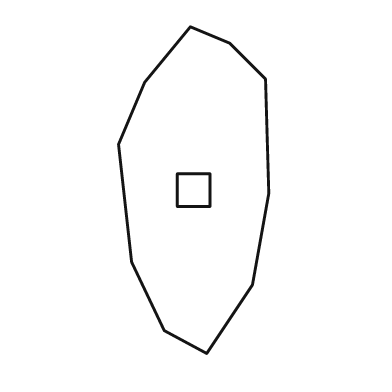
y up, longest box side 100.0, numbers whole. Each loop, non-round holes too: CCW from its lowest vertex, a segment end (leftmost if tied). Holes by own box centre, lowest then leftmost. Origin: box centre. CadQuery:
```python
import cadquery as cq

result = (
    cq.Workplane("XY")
    .moveTo(4.0, -50.0)
    .lineTo(18.0, -29.0)
    .lineTo(23.0, -1.0)
    .lineTo(22.0, 34.0)
    .lineTo(11.0, 45.0)
    .lineTo(-1.0, 50.0)
    .lineTo(-15.0, 33.0)
    .lineTo(-23.0, 14.0)
    .lineTo(-19.0, -22.0)
    .lineTo(-9.0, -43.0)
    .close()
    .moveTo(-5.0, -5.0)
    .lineTo(5.0, -5.0)
    .lineTo(5.0, 5.0)
    .lineTo(-5.0, 5.0)
    .close()
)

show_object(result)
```